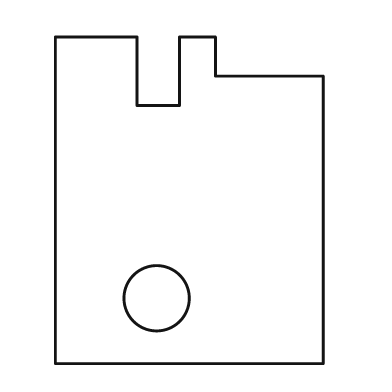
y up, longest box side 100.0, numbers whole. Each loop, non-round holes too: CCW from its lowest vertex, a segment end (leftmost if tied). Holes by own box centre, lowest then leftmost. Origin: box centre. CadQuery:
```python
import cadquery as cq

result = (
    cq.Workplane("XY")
    .moveTo(-41.0, -50.0)
    .lineTo(41.0, -50.0)
    .lineTo(41.0, 38.0)
    .lineTo(8.0, 38.0)
    .lineTo(8.0, 50.0)
    .lineTo(-3.0, 50.0)
    .lineTo(-3.0, 29.0)
    .lineTo(-16.0, 29.0)
    .lineTo(-16.0, 50.0)
    .lineTo(-41.0, 50.0)
    .close()
    .moveTo(-10.0, -30.0)
    .circle(10.0)
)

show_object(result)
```